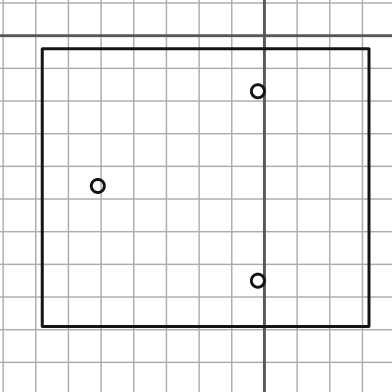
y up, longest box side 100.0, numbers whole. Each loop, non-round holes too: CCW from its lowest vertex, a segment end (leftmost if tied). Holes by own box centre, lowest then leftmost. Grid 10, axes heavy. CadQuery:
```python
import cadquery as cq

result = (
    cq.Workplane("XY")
    .moveTo(-68.0, -89.0)
    .lineTo(32.0, -89.0)
    .lineTo(32.0, -4.0)
    .lineTo(-68.0, -4.0)
    .close()
    .moveTo(-2.0, -75.0)
    .circle(2.0)
    .moveTo(-51.0, -46.0)
    .circle(2.0)
    .moveTo(-2.0, -17.0)
    .circle(2.0)
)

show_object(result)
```